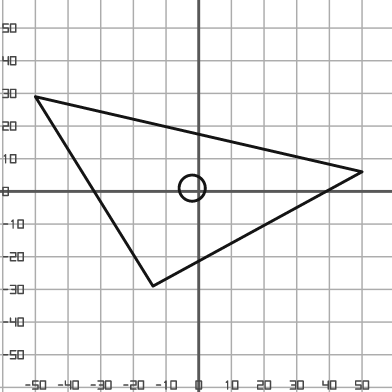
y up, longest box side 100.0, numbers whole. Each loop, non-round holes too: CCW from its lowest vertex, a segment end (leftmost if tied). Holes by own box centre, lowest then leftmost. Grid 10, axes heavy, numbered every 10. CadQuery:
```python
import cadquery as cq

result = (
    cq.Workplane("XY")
    .moveTo(-14.0, -29.0)
    .lineTo(50.0, 6.0)
    .lineTo(-50.0, 29.0)
    .close()
    .moveTo(-2.0, 1.0)
    .circle(4.0)
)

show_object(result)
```